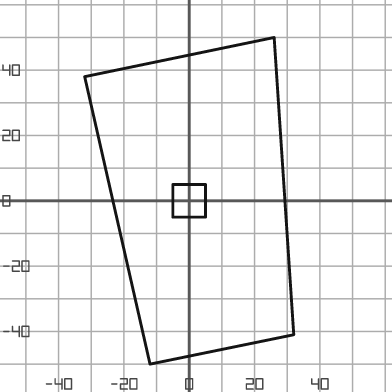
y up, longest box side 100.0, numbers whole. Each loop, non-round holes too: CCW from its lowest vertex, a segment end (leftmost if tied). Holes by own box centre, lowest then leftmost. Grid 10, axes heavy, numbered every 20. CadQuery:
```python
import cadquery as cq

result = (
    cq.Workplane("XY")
    .moveTo(-12.0, -50.0)
    .lineTo(32.0, -41.0)
    .lineTo(26.0, 50.0)
    .lineTo(-32.0, 38.0)
    .close()
    .moveTo(-5.0, -5.0)
    .lineTo(5.0, -5.0)
    .lineTo(5.0, 5.0)
    .lineTo(-5.0, 5.0)
    .close()
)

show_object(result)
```